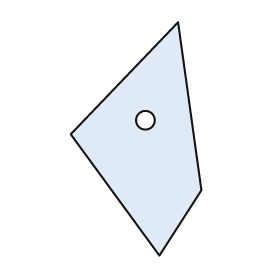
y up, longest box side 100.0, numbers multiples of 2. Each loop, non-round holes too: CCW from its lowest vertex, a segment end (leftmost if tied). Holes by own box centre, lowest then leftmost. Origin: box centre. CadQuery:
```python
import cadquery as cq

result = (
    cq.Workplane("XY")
    .moveTo(10.0, -50.0)
    .lineTo(28.0, -22.0)
    .lineTo(18.0, 50.0)
    .lineTo(-28.0, 2.0)
    .close()
    .moveTo(4.0, 8.0)
    .circle(4.0)
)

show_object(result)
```